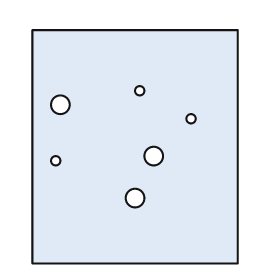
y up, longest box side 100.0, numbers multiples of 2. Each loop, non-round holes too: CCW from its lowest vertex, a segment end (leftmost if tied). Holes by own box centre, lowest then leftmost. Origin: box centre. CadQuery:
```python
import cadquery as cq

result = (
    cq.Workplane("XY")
    .moveTo(-44.0, -50.0)
    .lineTo(44.0, -50.0)
    .lineTo(44.0, 50.0)
    .lineTo(-44.0, 50.0)
    .close()
    .moveTo(0.0, -22.0)
    .circle(4.0)
    .moveTo(-34.0, -6.0)
    .circle(2.0)
    .moveTo(8.0, -4.0)
    .circle(4.0)
    .moveTo(24.0, 12.0)
    .circle(2.0)
    .moveTo(-32.0, 18.0)
    .circle(4.0)
    .moveTo(2.0, 24.0)
    .circle(2.0)
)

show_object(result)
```